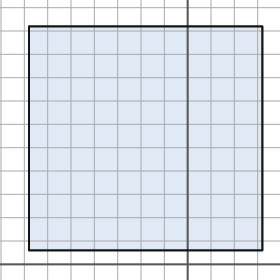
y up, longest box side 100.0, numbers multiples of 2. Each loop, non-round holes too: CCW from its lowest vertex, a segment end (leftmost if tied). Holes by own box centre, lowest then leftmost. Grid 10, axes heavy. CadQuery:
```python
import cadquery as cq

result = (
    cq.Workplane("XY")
    .moveTo(-68.0, 6.0)
    .lineTo(32.0, 6.0)
    .lineTo(32.0, 102.0)
    .lineTo(-68.0, 102.0)
    .close()
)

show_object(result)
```